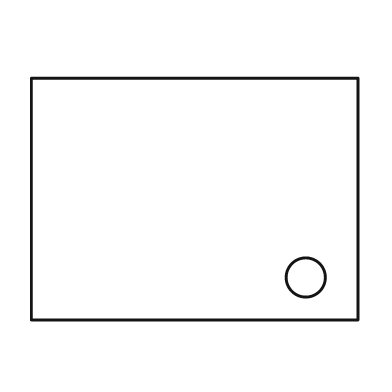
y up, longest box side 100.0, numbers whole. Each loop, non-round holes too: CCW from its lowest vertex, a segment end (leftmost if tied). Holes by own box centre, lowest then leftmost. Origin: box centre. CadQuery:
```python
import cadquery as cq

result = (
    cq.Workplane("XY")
    .moveTo(-50.0, -37.0)
    .lineTo(50.0, -37.0)
    .lineTo(50.0, 37.0)
    .lineTo(-50.0, 37.0)
    .close()
    .moveTo(34.0, -24.0)
    .circle(6.0)
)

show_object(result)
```